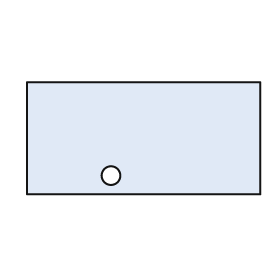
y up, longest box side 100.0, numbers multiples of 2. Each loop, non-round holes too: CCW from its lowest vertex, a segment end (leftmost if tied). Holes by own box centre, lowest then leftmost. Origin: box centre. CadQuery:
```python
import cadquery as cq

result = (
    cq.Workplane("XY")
    .moveTo(-50.0, -24.0)
    .lineTo(50.0, -24.0)
    .lineTo(50.0, 24.0)
    .lineTo(-50.0, 24.0)
    .close()
    .moveTo(-14.0, -16.0)
    .circle(4.0)
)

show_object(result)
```